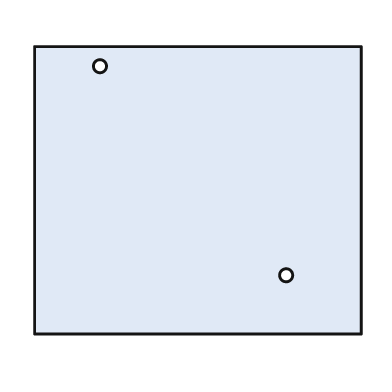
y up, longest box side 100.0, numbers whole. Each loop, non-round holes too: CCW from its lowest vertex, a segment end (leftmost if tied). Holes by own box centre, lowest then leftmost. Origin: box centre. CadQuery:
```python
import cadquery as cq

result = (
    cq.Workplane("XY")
    .moveTo(-50.0, -44.0)
    .lineTo(50.0, -44.0)
    .lineTo(50.0, 44.0)
    .lineTo(-50.0, 44.0)
    .close()
    .moveTo(27.0, -26.0)
    .circle(2.0)
    .moveTo(-30.0, 38.0)
    .circle(2.0)
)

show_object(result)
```